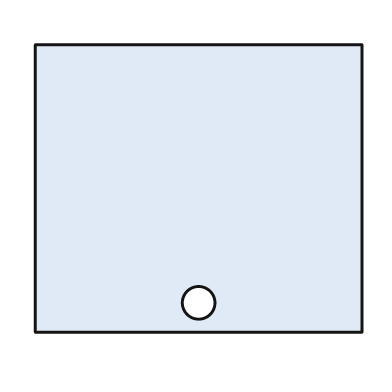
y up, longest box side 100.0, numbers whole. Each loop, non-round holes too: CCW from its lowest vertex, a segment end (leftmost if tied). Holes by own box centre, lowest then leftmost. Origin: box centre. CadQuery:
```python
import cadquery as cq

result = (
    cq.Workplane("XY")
    .moveTo(-50.0, -44.0)
    .lineTo(50.0, -44.0)
    .lineTo(50.0, 44.0)
    .lineTo(-50.0, 44.0)
    .close()
    .moveTo(0.0, -35.0)
    .circle(5.0)
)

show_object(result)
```